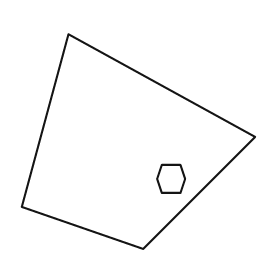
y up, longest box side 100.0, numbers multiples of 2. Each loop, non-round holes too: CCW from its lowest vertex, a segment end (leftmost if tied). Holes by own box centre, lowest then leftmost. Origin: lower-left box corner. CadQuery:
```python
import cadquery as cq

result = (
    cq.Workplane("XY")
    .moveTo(52.0, 0.0)
    .lineTo(100.0, 48.0)
    .lineTo(20.0, 92.0)
    .lineTo(0.0, 18.0)
    .close()
    .moveTo(60.0, 24.0)
    .lineTo(68.0, 24.0)
    .lineTo(70.0, 30.0)
    .lineTo(68.0, 36.0)
    .lineTo(60.0, 36.0)
    .lineTo(58.0, 30.0)
    .close()
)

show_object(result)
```